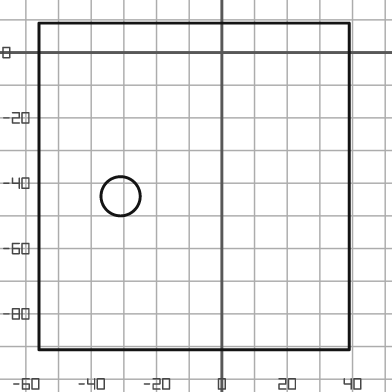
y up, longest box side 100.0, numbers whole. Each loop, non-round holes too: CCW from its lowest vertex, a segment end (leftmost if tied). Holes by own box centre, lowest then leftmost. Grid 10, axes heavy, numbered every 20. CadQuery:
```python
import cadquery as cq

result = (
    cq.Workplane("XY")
    .moveTo(-56.0, -91.0)
    .lineTo(39.0, -91.0)
    .lineTo(39.0, 9.0)
    .lineTo(-56.0, 9.0)
    .close()
    .moveTo(-31.0, -44.0)
    .circle(6.0)
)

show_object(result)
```